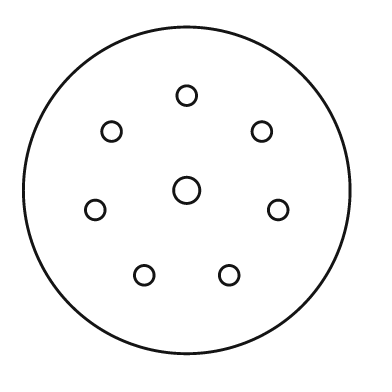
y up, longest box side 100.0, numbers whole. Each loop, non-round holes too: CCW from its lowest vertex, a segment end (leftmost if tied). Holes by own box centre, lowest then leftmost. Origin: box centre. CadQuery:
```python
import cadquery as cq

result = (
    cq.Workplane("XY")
    .moveTo(0.0, 0.0)
    .circle(50.0)
    .moveTo(-13.0, -26.0)
    .circle(3.0)
    .moveTo(13.0, -26.0)
    .circle(3.0)
    .moveTo(-28.0, -6.0)
    .circle(3.0)
    .moveTo(28.0, -6.0)
    .circle(3.0)
    .moveTo(0.0, 0.0)
    .circle(4.0)
    .moveTo(-23.0, 18.0)
    .circle(3.0)
    .moveTo(23.0, 18.0)
    .circle(3.0)
    .moveTo(0.0, 29.0)
    .circle(3.0)
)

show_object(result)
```